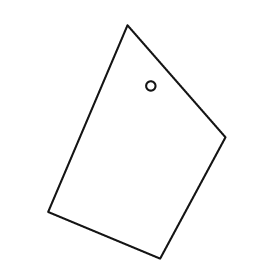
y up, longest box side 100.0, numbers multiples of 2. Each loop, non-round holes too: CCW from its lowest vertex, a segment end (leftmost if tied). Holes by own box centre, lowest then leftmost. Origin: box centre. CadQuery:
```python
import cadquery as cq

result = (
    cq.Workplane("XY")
    .moveTo(10.0, -50.0)
    .lineTo(38.0, 2.0)
    .lineTo(-4.0, 50.0)
    .lineTo(-38.0, -30.0)
    .close()
    .moveTo(6.0, 24.0)
    .circle(2.0)
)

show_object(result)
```